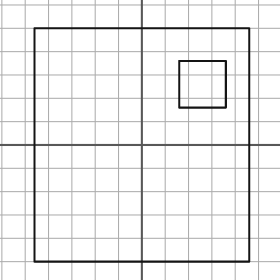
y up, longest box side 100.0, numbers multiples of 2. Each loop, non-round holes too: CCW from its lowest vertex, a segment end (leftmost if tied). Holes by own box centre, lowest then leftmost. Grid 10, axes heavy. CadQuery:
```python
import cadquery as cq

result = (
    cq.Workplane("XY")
    .moveTo(-46.0, -50.0)
    .lineTo(46.0, -50.0)
    .lineTo(46.0, 50.0)
    .lineTo(-46.0, 50.0)
    .close()
    .moveTo(16.0, 16.0)
    .lineTo(36.0, 16.0)
    .lineTo(36.0, 36.0)
    .lineTo(16.0, 36.0)
    .close()
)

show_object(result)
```